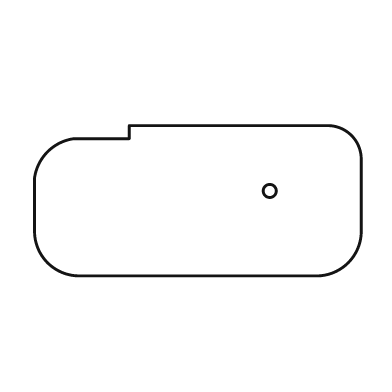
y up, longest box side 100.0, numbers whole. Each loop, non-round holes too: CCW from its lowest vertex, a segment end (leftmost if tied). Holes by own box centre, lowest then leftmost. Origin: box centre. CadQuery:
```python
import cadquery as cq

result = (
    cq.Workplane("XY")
    .moveTo(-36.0, -23.0)
    .lineTo(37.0, -23.0)
    .threePointArc((46.0, -19.0), (50.0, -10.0))
    .lineTo(50.0, 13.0)
    .threePointArc((47.0, 20.0), (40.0, 23.0))
    .lineTo(-21.0, 23.0)
    .lineTo(-21.0, 19.0)
    .lineTo(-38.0, 19.0)
    .threePointArc((-46.0, 15.0), (-50.0, 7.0))
    .lineTo(-50.0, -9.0)
    .threePointArc((-46.0, -19.0), (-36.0, -23.0))
    .close()
    .moveTo(22.0, 3.0)
    .circle(2.0)
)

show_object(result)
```